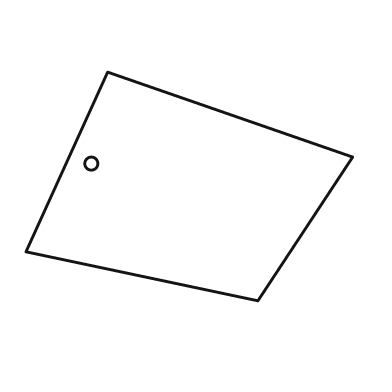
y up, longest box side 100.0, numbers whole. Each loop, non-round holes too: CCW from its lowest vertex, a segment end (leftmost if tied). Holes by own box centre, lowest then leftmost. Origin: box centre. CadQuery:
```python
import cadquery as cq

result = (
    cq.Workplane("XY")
    .moveTo(21.0, -35.0)
    .lineTo(50.0, 9.0)
    .lineTo(-25.0, 35.0)
    .lineTo(-50.0, -20.0)
    .close()
    .moveTo(-30.0, 7.0)
    .circle(2.0)
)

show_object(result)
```